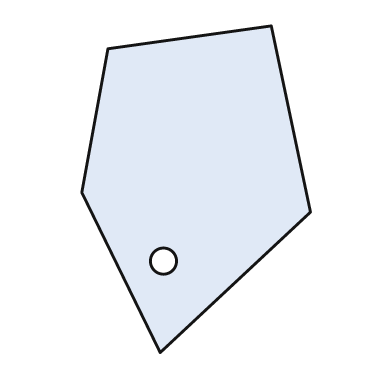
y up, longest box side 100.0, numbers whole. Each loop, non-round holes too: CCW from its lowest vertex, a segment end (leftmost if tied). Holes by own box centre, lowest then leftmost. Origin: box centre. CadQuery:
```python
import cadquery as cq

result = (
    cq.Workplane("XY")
    .moveTo(-11.0, -50.0)
    .lineTo(35.0, -7.0)
    .lineTo(23.0, 50.0)
    .lineTo(-27.0, 43.0)
    .lineTo(-35.0, -1.0)
    .close()
    .moveTo(-10.0, -22.0)
    .circle(4.0)
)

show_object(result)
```